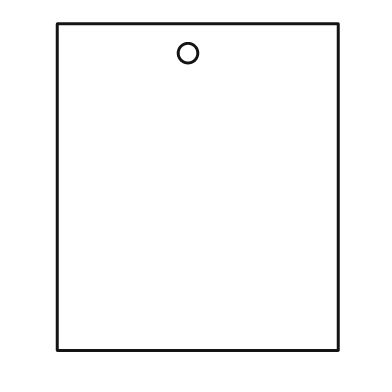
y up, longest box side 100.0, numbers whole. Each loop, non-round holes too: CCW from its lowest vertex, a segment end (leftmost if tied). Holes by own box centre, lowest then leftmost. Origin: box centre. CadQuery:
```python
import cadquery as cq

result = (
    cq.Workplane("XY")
    .moveTo(-43.0, -50.0)
    .lineTo(43.0, -50.0)
    .lineTo(43.0, 50.0)
    .lineTo(-43.0, 50.0)
    .close()
    .moveTo(-3.0, 41.0)
    .circle(3.0)
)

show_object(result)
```